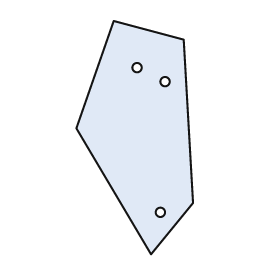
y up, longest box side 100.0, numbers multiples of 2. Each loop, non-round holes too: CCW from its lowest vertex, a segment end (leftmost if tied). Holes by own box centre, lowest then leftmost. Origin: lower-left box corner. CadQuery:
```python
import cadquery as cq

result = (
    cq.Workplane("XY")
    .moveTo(32.0, 0.0)
    .lineTo(50.0, 22.0)
    .lineTo(46.0, 92.0)
    .lineTo(16.0, 100.0)
    .lineTo(0.0, 54.0)
    .close()
    .moveTo(36.0, 18.0)
    .circle(2.0)
    .moveTo(38.0, 74.0)
    .circle(2.0)
    .moveTo(26.0, 80.0)
    .circle(2.0)
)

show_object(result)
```